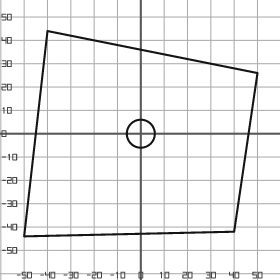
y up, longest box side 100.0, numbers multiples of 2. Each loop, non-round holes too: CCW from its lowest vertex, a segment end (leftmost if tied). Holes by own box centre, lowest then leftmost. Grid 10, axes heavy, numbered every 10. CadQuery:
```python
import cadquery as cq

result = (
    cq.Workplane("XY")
    .moveTo(-50.0, -44.0)
    .lineTo(40.0, -42.0)
    .lineTo(50.0, 26.0)
    .lineTo(-40.0, 44.0)
    .close()
    .moveTo(0.0, 0.0)
    .circle(6.0)
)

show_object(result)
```